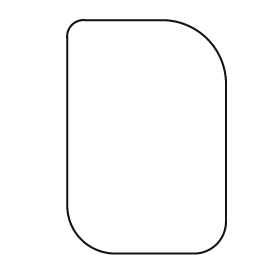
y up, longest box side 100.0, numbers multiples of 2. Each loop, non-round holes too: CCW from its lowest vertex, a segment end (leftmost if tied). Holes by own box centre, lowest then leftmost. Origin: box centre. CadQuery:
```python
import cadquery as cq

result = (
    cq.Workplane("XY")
    .moveTo(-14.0, -50.0)
    .lineTo(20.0, -50.0)
    .threePointArc((30.0, -46.0), (34.0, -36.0))
    .lineTo(34.0, 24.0)
    .threePointArc((26.0, 42.0), (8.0, 50.0))
    .lineTo(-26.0, 50.0)
    .threePointArc((-32.0, 48.0), (-34.0, 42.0))
    .lineTo(-34.0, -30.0)
    .threePointArc((-28.0, -44.0), (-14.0, -50.0))
    .close()
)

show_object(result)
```